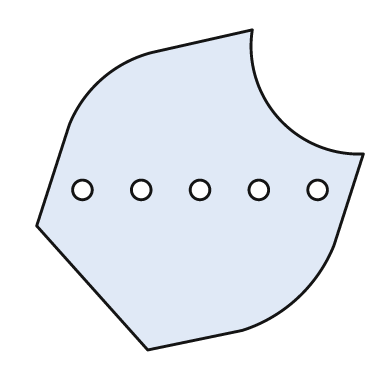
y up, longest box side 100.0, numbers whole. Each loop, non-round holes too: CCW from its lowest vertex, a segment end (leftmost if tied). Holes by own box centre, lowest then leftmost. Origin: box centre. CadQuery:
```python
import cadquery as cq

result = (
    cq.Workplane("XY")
    .moveTo(-16.0, -49.0)
    .lineTo(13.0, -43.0)
    .threePointArc((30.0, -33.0), (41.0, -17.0))
    .lineTo(50.0, 11.0)
    .threePointArc((24.0, 22.0), (16.0, 49.0))
    .lineTo(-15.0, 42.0)
    .threePointArc((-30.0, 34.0), (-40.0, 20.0))
    .lineTo(-50.0, -11.0)
    .close()
    .moveTo(-36.0, 0.0)
    .circle(3.0)
    .moveTo(-18.0, 0.0)
    .circle(3.0)
    .moveTo(0.0, 0.0)
    .circle(3.0)
    .moveTo(18.0, 0.0)
    .circle(3.0)
    .moveTo(36.0, 0.0)
    .circle(3.0)
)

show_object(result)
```